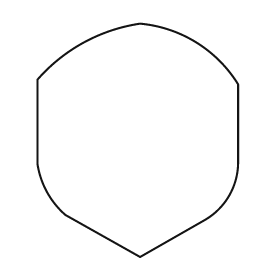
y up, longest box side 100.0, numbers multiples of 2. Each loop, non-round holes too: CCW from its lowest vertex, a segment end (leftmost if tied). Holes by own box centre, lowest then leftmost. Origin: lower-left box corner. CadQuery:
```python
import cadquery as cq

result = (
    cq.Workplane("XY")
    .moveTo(44.0, 0.0)
    .lineTo(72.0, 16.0)
    .threePointArc((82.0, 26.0), (86.0, 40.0))
    .lineTo(86.0, 74.0)
    .threePointArc((68.0, 92.0), (44.0, 100.0))
    .threePointArc((20.0, 92.0), (0.0, 76.0))
    .lineTo(0.0, 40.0)
    .threePointArc((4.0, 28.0), (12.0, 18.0))
    .close()
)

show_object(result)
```